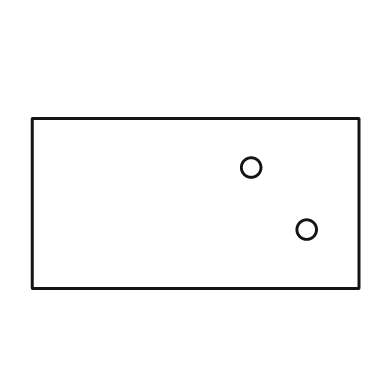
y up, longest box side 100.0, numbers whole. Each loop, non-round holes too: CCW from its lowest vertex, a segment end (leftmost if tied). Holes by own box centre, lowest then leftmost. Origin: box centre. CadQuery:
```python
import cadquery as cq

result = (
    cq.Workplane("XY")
    .moveTo(-50.0, -26.0)
    .lineTo(50.0, -26.0)
    .lineTo(50.0, 26.0)
    .lineTo(-50.0, 26.0)
    .close()
    .moveTo(34.0, -8.0)
    .circle(3.0)
    .moveTo(17.0, 11.0)
    .circle(3.0)
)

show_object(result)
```